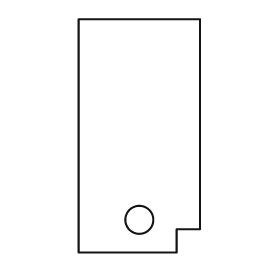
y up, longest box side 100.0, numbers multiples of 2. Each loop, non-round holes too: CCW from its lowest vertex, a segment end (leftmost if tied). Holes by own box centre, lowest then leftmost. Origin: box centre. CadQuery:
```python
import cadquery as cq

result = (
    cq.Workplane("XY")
    .moveTo(-26.0, -50.0)
    .lineTo(16.0, -50.0)
    .lineTo(16.0, -40.0)
    .lineTo(26.0, -40.0)
    .lineTo(26.0, 50.0)
    .lineTo(-26.0, 50.0)
    .close()
    .moveTo(0.0, -36.0)
    .circle(6.0)
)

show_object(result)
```